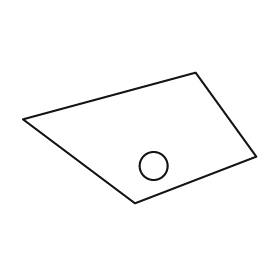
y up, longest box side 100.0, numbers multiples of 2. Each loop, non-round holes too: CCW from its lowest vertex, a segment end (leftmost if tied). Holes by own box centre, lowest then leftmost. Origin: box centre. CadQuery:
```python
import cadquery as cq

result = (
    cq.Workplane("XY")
    .moveTo(-2.0, -28.0)
    .lineTo(50.0, -8.0)
    .lineTo(24.0, 28.0)
    .lineTo(-50.0, 8.0)
    .close()
    .moveTo(6.0, -12.0)
    .circle(6.0)
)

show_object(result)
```